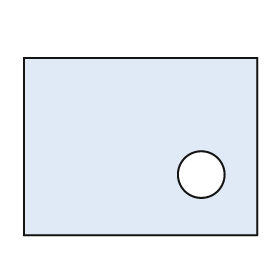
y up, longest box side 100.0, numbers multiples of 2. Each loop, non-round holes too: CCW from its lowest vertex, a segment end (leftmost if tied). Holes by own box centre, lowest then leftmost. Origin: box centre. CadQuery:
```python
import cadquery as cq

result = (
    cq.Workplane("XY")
    .moveTo(-50.0, -38.0)
    .lineTo(50.0, -38.0)
    .lineTo(50.0, 38.0)
    .lineTo(-50.0, 38.0)
    .close()
    .moveTo(26.0, -12.0)
    .circle(10.0)
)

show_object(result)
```